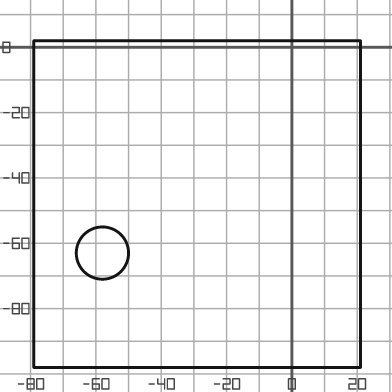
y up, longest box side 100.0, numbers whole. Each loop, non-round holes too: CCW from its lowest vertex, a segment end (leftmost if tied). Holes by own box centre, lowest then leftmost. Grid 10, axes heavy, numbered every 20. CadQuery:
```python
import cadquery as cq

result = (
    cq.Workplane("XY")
    .moveTo(-79.0, -98.0)
    .lineTo(21.0, -98.0)
    .lineTo(21.0, 2.0)
    .lineTo(-79.0, 2.0)
    .close()
    .moveTo(-58.0, -63.0)
    .circle(8.0)
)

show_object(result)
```